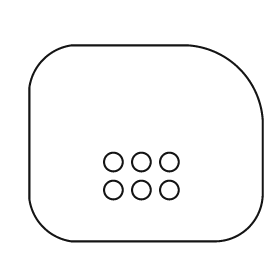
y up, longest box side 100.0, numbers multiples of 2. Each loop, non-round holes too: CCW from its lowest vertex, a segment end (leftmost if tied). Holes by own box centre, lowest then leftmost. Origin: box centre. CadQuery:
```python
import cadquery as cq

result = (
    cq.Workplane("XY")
    .moveTo(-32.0, -42.0)
    .lineTo(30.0, -42.0)
    .threePointArc((44.0, -36.0), (50.0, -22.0))
    .lineTo(50.0, 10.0)
    .threePointArc((40.0, 32.0), (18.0, 42.0))
    .lineTo(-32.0, 42.0)
    .threePointArc((-44.0, 36.0), (-50.0, 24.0))
    .lineTo(-50.0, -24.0)
    .threePointArc((-44.0, -36.0), (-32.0, -42.0))
    .close()
    .moveTo(-14.0, -20.0)
    .circle(4.0)
    .moveTo(-2.0, -20.0)
    .circle(4.0)
    .moveTo(10.0, -20.0)
    .circle(4.0)
    .moveTo(-14.0, -8.0)
    .circle(4.0)
    .moveTo(-2.0, -8.0)
    .circle(4.0)
    .moveTo(10.0, -8.0)
    .circle(4.0)
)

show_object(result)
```